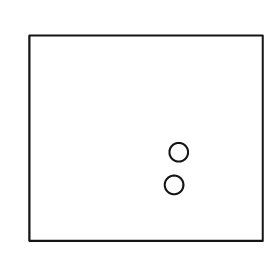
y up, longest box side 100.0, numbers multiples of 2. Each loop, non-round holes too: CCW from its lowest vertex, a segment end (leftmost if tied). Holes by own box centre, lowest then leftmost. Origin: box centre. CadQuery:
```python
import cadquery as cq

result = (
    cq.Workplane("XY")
    .moveTo(-50.0, -44.0)
    .lineTo(50.0, -44.0)
    .lineTo(50.0, 44.0)
    .lineTo(-50.0, 44.0)
    .close()
    .moveTo(12.0, -20.0)
    .circle(4.0)
    .moveTo(14.0, -6.0)
    .circle(4.0)
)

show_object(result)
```